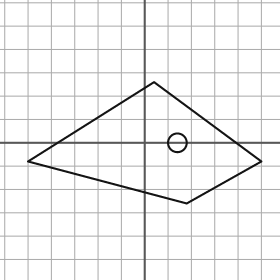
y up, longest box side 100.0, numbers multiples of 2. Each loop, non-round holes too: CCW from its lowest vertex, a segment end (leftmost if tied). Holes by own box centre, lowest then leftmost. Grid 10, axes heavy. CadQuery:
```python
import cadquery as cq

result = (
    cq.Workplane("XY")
    .moveTo(18.0, -26.0)
    .lineTo(50.0, -8.0)
    .lineTo(4.0, 26.0)
    .lineTo(-50.0, -8.0)
    .close()
    .moveTo(14.0, 0.0)
    .circle(4.0)
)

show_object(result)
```